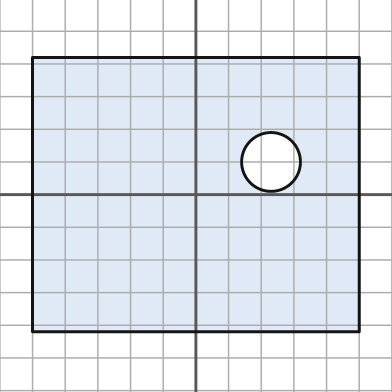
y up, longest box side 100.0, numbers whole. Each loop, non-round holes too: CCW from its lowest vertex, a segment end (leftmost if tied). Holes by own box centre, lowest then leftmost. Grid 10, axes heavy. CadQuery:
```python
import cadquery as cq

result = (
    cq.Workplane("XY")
    .moveTo(-50.0, -42.0)
    .lineTo(50.0, -42.0)
    .lineTo(50.0, 42.0)
    .lineTo(-50.0, 42.0)
    .close()
    .moveTo(23.0, 10.0)
    .circle(9.0)
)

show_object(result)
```